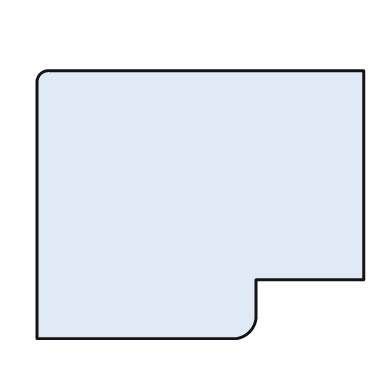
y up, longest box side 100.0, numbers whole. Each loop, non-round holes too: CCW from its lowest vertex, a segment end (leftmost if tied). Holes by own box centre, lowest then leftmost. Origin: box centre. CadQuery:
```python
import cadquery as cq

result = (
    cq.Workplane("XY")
    .moveTo(-50.0, -41.0)
    .lineTo(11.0, -41.0)
    .threePointArc((15.0, -39.0), (17.0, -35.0))
    .lineTo(17.0, -23.0)
    .lineTo(50.0, -23.0)
    .lineTo(50.0, 41.0)
    .lineTo(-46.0, 41.0)
    .threePointArc((-49.0, 40.0), (-50.0, 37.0))
    .close()
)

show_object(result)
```